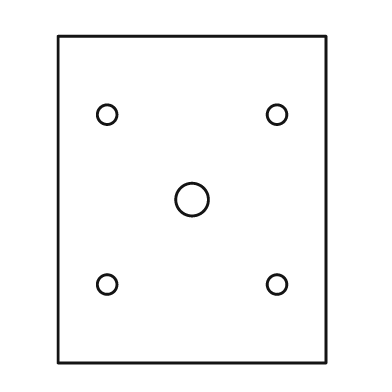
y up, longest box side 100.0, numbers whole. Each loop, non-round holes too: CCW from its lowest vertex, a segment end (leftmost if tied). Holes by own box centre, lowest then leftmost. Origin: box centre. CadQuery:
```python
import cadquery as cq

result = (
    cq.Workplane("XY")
    .moveTo(-41.0, -50.0)
    .lineTo(41.0, -50.0)
    .lineTo(41.0, 50.0)
    .lineTo(-41.0, 50.0)
    .close()
    .moveTo(-26.0, -26.0)
    .circle(3.0)
    .moveTo(26.0, -26.0)
    .circle(3.0)
    .moveTo(0.0, 0.0)
    .circle(5.0)
    .moveTo(-26.0, 26.0)
    .circle(3.0)
    .moveTo(26.0, 26.0)
    .circle(3.0)
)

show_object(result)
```